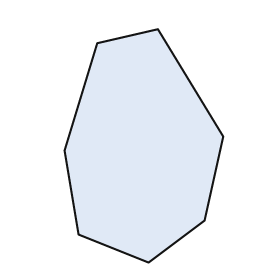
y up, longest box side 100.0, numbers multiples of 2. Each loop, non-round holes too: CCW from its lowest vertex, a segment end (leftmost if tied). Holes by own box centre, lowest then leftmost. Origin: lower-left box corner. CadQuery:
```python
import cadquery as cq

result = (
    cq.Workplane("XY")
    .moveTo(36.0, 0.0)
    .lineTo(60.0, 18.0)
    .lineTo(68.0, 54.0)
    .lineTo(40.0, 100.0)
    .lineTo(14.0, 94.0)
    .lineTo(0.0, 48.0)
    .lineTo(6.0, 12.0)
    .close()
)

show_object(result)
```